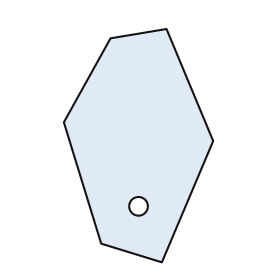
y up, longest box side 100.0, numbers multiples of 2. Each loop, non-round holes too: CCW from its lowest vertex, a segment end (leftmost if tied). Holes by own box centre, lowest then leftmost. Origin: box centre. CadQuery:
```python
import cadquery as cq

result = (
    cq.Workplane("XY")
    .moveTo(10.0, -50.0)
    .lineTo(32.0, 2.0)
    .lineTo(12.0, 50.0)
    .lineTo(-12.0, 46.0)
    .lineTo(-32.0, 10.0)
    .lineTo(-16.0, -42.0)
    .close()
    .moveTo(0.0, -26.0)
    .circle(4.0)
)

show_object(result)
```